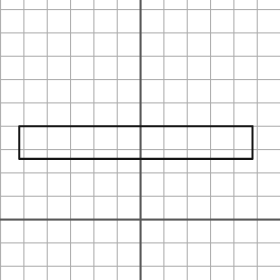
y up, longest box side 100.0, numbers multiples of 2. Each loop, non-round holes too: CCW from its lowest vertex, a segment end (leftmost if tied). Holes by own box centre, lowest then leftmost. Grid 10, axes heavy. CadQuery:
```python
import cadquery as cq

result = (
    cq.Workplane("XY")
    .moveTo(-52.0, 26.0)
    .lineTo(48.0, 26.0)
    .lineTo(48.0, 40.0)
    .lineTo(-52.0, 40.0)
    .close()
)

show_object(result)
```